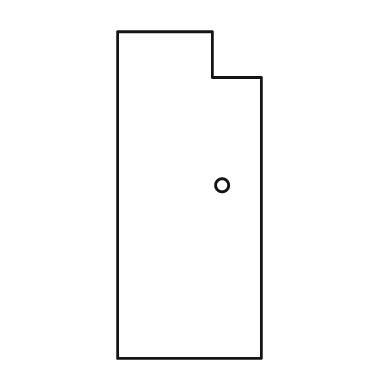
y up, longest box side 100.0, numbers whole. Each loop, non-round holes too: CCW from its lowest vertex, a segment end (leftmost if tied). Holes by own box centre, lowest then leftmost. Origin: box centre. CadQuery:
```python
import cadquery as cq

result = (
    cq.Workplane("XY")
    .moveTo(-22.0, -50.0)
    .lineTo(22.0, -50.0)
    .lineTo(22.0, 36.0)
    .lineTo(7.0, 36.0)
    .lineTo(7.0, 50.0)
    .lineTo(-22.0, 50.0)
    .close()
    .moveTo(10.0, 3.0)
    .circle(2.0)
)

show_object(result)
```